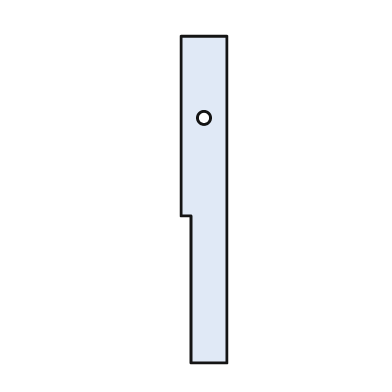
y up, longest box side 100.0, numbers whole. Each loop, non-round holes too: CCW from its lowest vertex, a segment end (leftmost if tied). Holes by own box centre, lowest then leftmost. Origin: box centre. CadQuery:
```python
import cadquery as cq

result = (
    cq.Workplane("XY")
    .moveTo(-4.0, -50.0)
    .lineTo(7.0, -50.0)
    .lineTo(7.0, 50.0)
    .lineTo(-7.0, 50.0)
    .lineTo(-7.0, -5.0)
    .lineTo(-4.0, -5.0)
    .close()
    .moveTo(0.0, 25.0)
    .circle(2.0)
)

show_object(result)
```